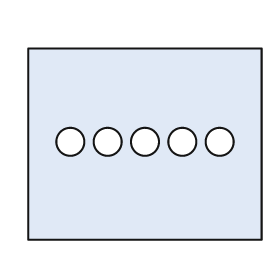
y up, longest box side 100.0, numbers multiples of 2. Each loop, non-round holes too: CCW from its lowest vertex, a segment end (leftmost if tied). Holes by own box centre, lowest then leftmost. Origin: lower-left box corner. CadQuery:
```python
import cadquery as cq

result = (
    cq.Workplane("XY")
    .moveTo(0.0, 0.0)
    .lineTo(100.0, 0.0)
    .lineTo(100.0, 82.0)
    .lineTo(0.0, 82.0)
    .close()
    .moveTo(18.0, 42.0)
    .circle(6.0)
    .moveTo(34.0, 42.0)
    .circle(6.0)
    .moveTo(50.0, 42.0)
    .circle(6.0)
    .moveTo(66.0, 42.0)
    .circle(6.0)
    .moveTo(82.0, 42.0)
    .circle(6.0)
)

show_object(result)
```